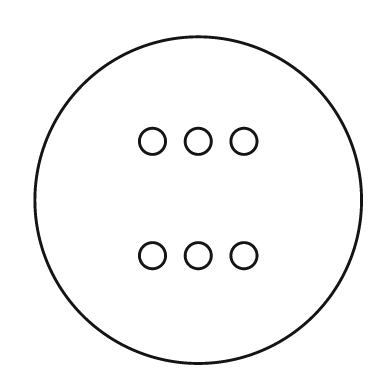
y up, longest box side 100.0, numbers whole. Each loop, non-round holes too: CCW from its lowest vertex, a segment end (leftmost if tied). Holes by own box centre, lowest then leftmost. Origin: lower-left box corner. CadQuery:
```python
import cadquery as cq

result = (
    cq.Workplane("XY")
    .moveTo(50.0, 50.0)
    .circle(50.0)
    .moveTo(36.0, 33.0)
    .circle(4.0)
    .moveTo(50.0, 33.0)
    .circle(4.0)
    .moveTo(64.0, 33.0)
    .circle(4.0)
    .moveTo(36.0, 68.0)
    .circle(4.0)
    .moveTo(50.0, 68.0)
    .circle(4.0)
    .moveTo(64.0, 68.0)
    .circle(4.0)
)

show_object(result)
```